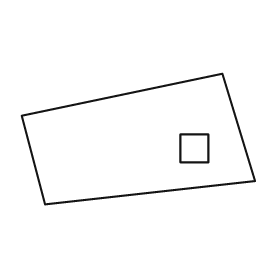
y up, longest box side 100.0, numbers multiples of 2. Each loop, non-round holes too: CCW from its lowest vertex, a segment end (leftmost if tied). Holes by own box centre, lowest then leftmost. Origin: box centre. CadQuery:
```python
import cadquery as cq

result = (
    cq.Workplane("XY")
    .moveTo(-40.0, -28.0)
    .lineTo(50.0, -18.0)
    .lineTo(36.0, 28.0)
    .lineTo(-50.0, 10.0)
    .close()
    .moveTo(18.0, -10.0)
    .lineTo(30.0, -10.0)
    .lineTo(30.0, 2.0)
    .lineTo(18.0, 2.0)
    .close()
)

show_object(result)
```